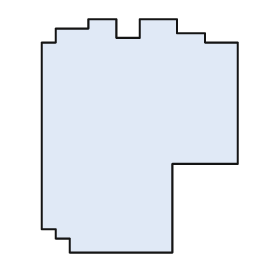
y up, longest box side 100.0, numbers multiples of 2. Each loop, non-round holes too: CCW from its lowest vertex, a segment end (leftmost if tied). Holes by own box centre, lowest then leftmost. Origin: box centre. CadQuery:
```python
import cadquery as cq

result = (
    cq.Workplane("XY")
    .moveTo(-30.0, -50.0)
    .lineTo(14.0, -50.0)
    .lineTo(14.0, -12.0)
    .lineTo(42.0, -12.0)
    .lineTo(42.0, 40.0)
    .lineTo(28.0, 40.0)
    .lineTo(28.0, 44.0)
    .lineTo(16.0, 44.0)
    .lineTo(16.0, 50.0)
    .lineTo(0.0, 50.0)
    .lineTo(0.0, 42.0)
    .lineTo(-10.0, 42.0)
    .lineTo(-10.0, 50.0)
    .lineTo(-22.0, 50.0)
    .lineTo(-22.0, 46.0)
    .lineTo(-36.0, 46.0)
    .lineTo(-36.0, 40.0)
    .lineTo(-42.0, 40.0)
    .lineTo(-42.0, -40.0)
    .lineTo(-36.0, -40.0)
    .lineTo(-36.0, -44.0)
    .lineTo(-30.0, -44.0)
    .close()
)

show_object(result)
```